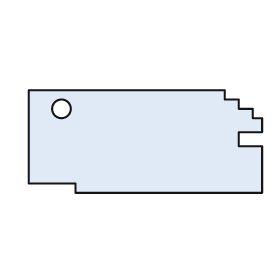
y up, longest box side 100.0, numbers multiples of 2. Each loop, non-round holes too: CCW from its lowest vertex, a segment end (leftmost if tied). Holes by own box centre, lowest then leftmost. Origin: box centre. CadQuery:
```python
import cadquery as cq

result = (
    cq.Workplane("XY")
    .moveTo(-30.0, -22.0)
    .lineTo(50.0, -22.0)
    .lineTo(50.0, -2.0)
    .lineTo(40.0, -2.0)
    .lineTo(40.0, 4.0)
    .lineTo(50.0, 4.0)
    .lineTo(50.0, 10.0)
    .lineTo(46.0, 10.0)
    .lineTo(46.0, 14.0)
    .lineTo(40.0, 14.0)
    .lineTo(40.0, 18.0)
    .lineTo(34.0, 18.0)
    .lineTo(34.0, 22.0)
    .lineTo(-50.0, 22.0)
    .lineTo(-50.0, -18.0)
    .lineTo(-30.0, -18.0)
    .close()
    .moveTo(-36.0, 14.0)
    .circle(4.0)
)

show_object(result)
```